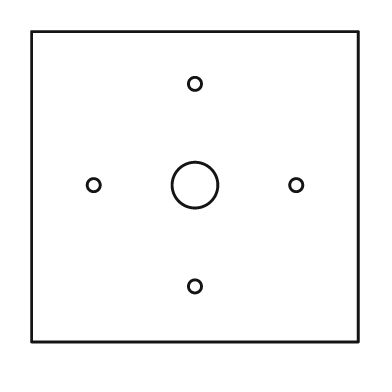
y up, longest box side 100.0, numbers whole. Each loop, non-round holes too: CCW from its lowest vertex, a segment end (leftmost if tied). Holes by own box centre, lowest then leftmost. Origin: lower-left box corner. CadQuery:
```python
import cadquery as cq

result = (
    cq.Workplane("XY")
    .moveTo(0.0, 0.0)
    .lineTo(100.0, 0.0)
    .lineTo(100.0, 95.0)
    .lineTo(0.0, 95.0)
    .close()
    .moveTo(50.0, 17.0)
    .circle(2.0)
    .moveTo(19.0, 48.0)
    .circle(2.0)
    .moveTo(50.0, 48.0)
    .circle(7.0)
    .moveTo(81.0, 48.0)
    .circle(2.0)
    .moveTo(50.0, 79.0)
    .circle(2.0)
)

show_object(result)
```